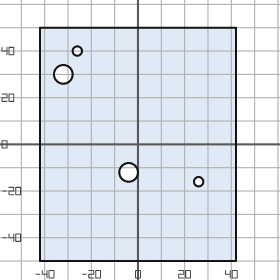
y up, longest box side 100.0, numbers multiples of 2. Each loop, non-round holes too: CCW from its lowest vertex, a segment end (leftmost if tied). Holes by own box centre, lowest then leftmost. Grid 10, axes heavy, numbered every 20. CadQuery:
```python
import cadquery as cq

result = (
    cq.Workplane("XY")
    .moveTo(-42.0, -50.0)
    .lineTo(42.0, -50.0)
    .lineTo(42.0, 50.0)
    .lineTo(-42.0, 50.0)
    .close()
    .moveTo(26.0, -16.0)
    .circle(2.0)
    .moveTo(-4.0, -12.0)
    .circle(4.0)
    .moveTo(-32.0, 30.0)
    .circle(4.0)
    .moveTo(-26.0, 40.0)
    .circle(2.0)
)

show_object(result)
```